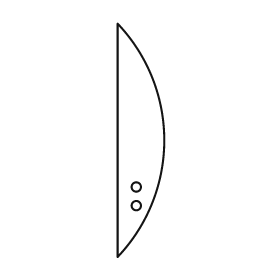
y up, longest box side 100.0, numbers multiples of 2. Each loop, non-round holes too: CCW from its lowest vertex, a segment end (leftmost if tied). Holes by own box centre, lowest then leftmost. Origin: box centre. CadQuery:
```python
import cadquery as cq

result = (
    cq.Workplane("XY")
    .moveTo(-10.0, -50.0)
    .threePointArc((10.0, 0.0), (-10.0, 50.0))
    .close()
    .moveTo(-2.0, -28.0)
    .circle(2.0)
    .moveTo(-2.0, -20.0)
    .circle(2.0)
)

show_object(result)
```